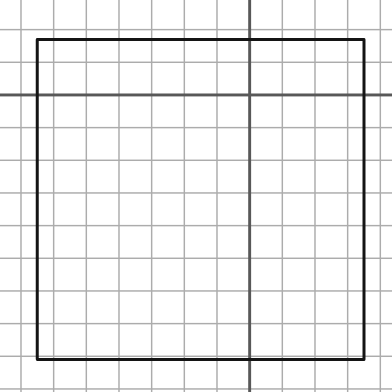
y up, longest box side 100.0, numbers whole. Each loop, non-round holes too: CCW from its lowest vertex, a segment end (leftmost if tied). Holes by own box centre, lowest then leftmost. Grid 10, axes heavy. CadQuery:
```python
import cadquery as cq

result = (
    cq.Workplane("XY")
    .moveTo(-65.0, -81.0)
    .lineTo(35.0, -81.0)
    .lineTo(35.0, 17.0)
    .lineTo(-65.0, 17.0)
    .close()
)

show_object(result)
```